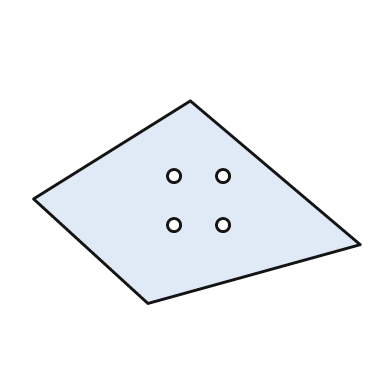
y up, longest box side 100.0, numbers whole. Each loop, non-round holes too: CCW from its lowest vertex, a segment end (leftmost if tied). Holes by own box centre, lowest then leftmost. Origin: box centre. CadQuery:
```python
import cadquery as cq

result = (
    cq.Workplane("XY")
    .moveTo(-15.0, -31.0)
    .lineTo(50.0, -13.0)
    .lineTo(-2.0, 31.0)
    .lineTo(-50.0, 1.0)
    .close()
    .moveTo(-7.0, -7.0)
    .circle(2.0)
    .moveTo(8.0, -7.0)
    .circle(2.0)
    .moveTo(-7.0, 8.0)
    .circle(2.0)
    .moveTo(8.0, 8.0)
    .circle(2.0)
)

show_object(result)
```